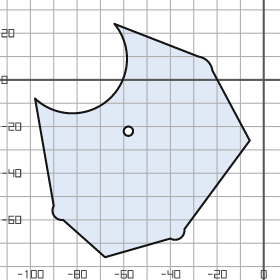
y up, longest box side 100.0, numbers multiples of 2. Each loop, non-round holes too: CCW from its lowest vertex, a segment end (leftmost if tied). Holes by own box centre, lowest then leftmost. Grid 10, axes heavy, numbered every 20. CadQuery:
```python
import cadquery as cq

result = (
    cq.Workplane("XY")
    .moveTo(-68.0, -76.0)
    .lineTo(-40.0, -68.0)
    .threePointArc((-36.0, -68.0), (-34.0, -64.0))
    .lineTo(-6.0, -26.0)
    .lineTo(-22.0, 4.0)
    .threePointArc((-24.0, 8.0), (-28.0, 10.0))
    .lineTo(-64.0, 24.0)
    .threePointArc((-66.0, -8.0), (-98.0, -8.0))
    .lineTo(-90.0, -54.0)
    .threePointArc((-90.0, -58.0), (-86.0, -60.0))
    .close()
    .moveTo(-58.0, -22.0)
    .circle(2.0)
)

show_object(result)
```